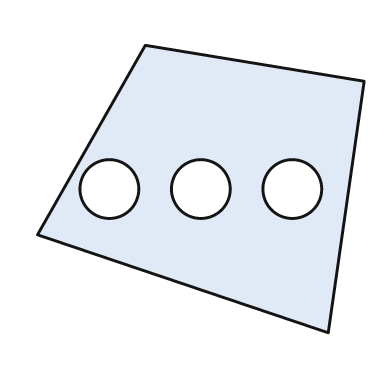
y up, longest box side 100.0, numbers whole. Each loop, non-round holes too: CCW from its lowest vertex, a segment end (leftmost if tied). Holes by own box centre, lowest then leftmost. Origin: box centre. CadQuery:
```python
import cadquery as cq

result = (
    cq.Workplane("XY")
    .moveTo(39.0, -44.0)
    .lineTo(50.0, 33.0)
    .lineTo(-17.0, 44.0)
    .lineTo(-50.0, -14.0)
    .close()
    .moveTo(-28.0, 0.0)
    .circle(9.0)
    .moveTo(0.0, 0.0)
    .circle(9.0)
    .moveTo(28.0, 0.0)
    .circle(9.0)
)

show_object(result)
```